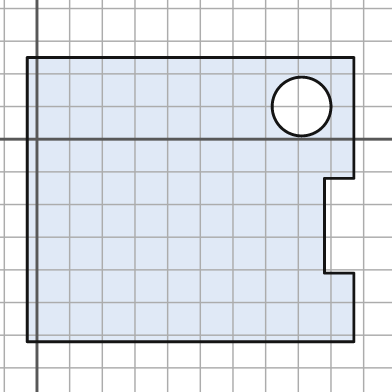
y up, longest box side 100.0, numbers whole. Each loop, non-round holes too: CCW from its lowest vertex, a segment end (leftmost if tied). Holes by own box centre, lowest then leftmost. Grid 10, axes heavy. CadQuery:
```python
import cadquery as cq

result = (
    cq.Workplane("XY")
    .moveTo(-3.0, -62.0)
    .lineTo(97.0, -62.0)
    .lineTo(97.0, -41.0)
    .lineTo(88.0, -41.0)
    .lineTo(88.0, -12.0)
    .lineTo(97.0, -12.0)
    .lineTo(97.0, 25.0)
    .lineTo(-3.0, 25.0)
    .close()
    .moveTo(81.0, 10.0)
    .circle(9.0)
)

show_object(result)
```